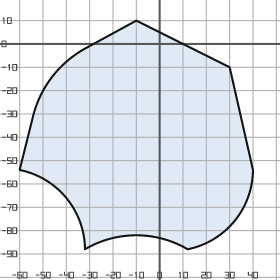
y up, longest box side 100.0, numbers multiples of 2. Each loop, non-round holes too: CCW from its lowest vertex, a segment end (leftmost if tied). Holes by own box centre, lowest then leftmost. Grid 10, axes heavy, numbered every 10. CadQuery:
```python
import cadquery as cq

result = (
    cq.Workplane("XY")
    .moveTo(-32.0, -88.0)
    .threePointArc((-10.0, -82.0), (12.0, -88.0))
    .threePointArc((32.0, -76.0), (40.0, -54.0))
    .lineTo(30.0, -10.0)
    .lineTo(-10.0, 10.0)
    .lineTo(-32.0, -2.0)
    .threePointArc((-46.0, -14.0), (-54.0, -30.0))
    .lineTo(-60.0, -54.0)
    .threePointArc((-40.0, -66.0), (-32.0, -88.0))
    .close()
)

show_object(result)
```